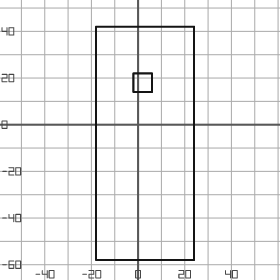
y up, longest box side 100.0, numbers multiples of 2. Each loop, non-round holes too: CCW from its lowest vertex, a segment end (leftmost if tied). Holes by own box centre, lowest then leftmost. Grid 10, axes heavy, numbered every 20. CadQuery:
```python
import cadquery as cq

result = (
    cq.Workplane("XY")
    .moveTo(-18.0, -58.0)
    .lineTo(24.0, -58.0)
    .lineTo(24.0, 42.0)
    .lineTo(-18.0, 42.0)
    .close()
    .moveTo(-2.0, 14.0)
    .lineTo(6.0, 14.0)
    .lineTo(6.0, 22.0)
    .lineTo(-2.0, 22.0)
    .close()
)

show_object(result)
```